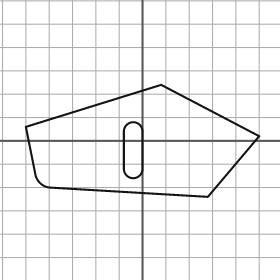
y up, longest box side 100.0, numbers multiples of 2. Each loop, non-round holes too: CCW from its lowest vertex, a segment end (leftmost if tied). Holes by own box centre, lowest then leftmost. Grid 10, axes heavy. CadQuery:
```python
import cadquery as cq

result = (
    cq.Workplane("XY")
    .moveTo(28.0, -24.0)
    .lineTo(50.0, 2.0)
    .lineTo(8.0, 24.0)
    .lineTo(-50.0, 6.0)
    .lineTo(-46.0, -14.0)
    .threePointArc((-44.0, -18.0), (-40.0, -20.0))
    .close()
    .moveTo(-8.0, -12.0)
    .threePointArc((-4.0, -16.0), (0.0, -12.0))
    .lineTo(0.0, 4.0)
    .threePointArc((-4.0, 8.0), (-8.0, 4.0))
    .close()
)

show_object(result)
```